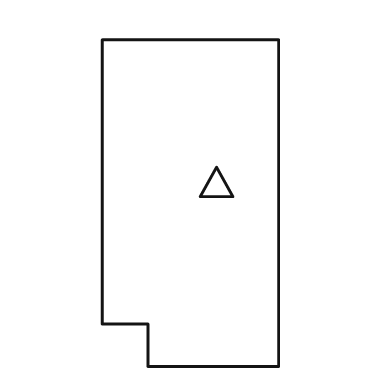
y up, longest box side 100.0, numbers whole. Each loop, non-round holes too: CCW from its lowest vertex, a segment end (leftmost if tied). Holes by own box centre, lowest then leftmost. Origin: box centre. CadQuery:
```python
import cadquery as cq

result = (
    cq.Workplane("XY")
    .moveTo(-13.0, -50.0)
    .lineTo(27.0, -50.0)
    .lineTo(27.0, 50.0)
    .lineTo(-27.0, 50.0)
    .lineTo(-27.0, -37.0)
    .lineTo(-13.0, -37.0)
    .close()
    .moveTo(3.0, 2.0)
    .lineTo(13.0, 2.0)
    .lineTo(8.0, 11.0)
    .close()
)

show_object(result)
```